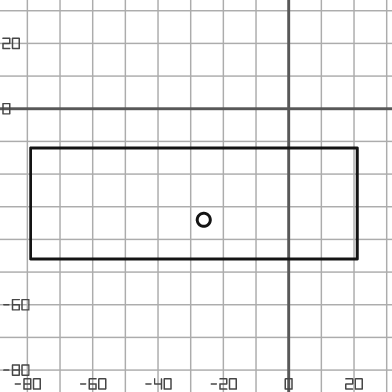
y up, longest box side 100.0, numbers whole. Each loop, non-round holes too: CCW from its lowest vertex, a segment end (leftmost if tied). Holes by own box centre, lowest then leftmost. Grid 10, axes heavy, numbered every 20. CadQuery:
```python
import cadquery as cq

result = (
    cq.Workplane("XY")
    .moveTo(-79.0, -46.0)
    .lineTo(21.0, -46.0)
    .lineTo(21.0, -12.0)
    .lineTo(-79.0, -12.0)
    .close()
    .moveTo(-26.0, -34.0)
    .circle(2.0)
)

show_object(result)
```